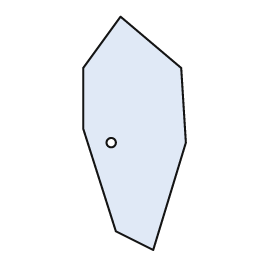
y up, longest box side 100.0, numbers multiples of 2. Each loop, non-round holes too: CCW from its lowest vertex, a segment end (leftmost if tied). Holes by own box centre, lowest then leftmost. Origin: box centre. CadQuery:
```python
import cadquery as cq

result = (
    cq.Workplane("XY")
    .moveTo(8.0, -50.0)
    .lineTo(22.0, -4.0)
    .lineTo(20.0, 28.0)
    .lineTo(-6.0, 50.0)
    .lineTo(-22.0, 28.0)
    .lineTo(-22.0, 2.0)
    .lineTo(-8.0, -42.0)
    .close()
    .moveTo(-10.0, -4.0)
    .circle(2.0)
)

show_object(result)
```